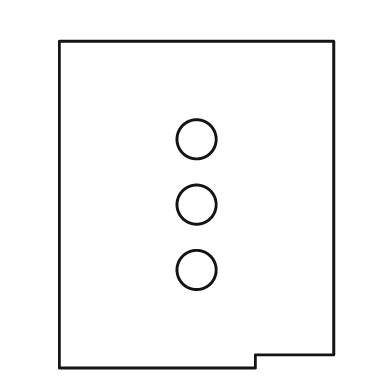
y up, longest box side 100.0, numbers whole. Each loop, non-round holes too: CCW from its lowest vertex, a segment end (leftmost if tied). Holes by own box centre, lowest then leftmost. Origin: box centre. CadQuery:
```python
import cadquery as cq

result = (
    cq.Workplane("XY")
    .moveTo(-42.0, -50.0)
    .lineTo(18.0, -50.0)
    .lineTo(18.0, -46.0)
    .lineTo(42.0, -46.0)
    .lineTo(42.0, 50.0)
    .lineTo(-42.0, 50.0)
    .close()
    .moveTo(0.0, -20.0)
    .circle(6.0)
    .moveTo(0.0, 0.0)
    .circle(6.0)
    .moveTo(0.0, 20.0)
    .circle(6.0)
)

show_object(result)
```